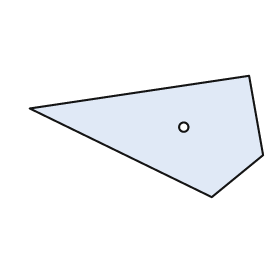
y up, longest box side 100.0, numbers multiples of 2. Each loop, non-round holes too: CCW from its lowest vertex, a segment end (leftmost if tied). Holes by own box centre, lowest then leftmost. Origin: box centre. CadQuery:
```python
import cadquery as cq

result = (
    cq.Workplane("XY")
    .moveTo(28.0, -26.0)
    .lineTo(50.0, -8.0)
    .lineTo(44.0, 26.0)
    .lineTo(-50.0, 12.0)
    .close()
    .moveTo(16.0, 4.0)
    .circle(2.0)
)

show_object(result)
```